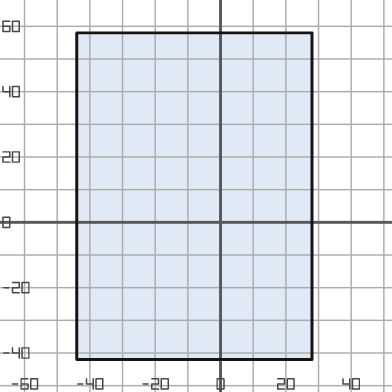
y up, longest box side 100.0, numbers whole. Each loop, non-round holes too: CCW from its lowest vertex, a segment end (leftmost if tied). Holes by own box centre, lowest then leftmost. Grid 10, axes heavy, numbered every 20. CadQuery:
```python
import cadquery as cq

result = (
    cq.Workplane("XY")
    .moveTo(-44.0, -42.0)
    .lineTo(28.0, -42.0)
    .lineTo(28.0, 58.0)
    .lineTo(-44.0, 58.0)
    .close()
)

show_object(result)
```